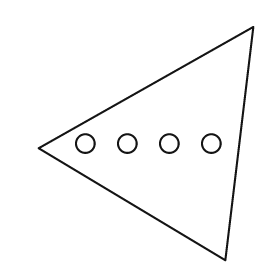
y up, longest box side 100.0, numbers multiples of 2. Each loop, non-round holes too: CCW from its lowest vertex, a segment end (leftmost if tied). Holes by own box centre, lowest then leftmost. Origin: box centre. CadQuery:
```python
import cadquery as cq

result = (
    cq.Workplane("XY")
    .moveTo(34.0, -50.0)
    .lineTo(46.0, 50.0)
    .lineTo(-46.0, -2.0)
    .close()
    .moveTo(-26.0, 0.0)
    .circle(4.0)
    .moveTo(-8.0, 0.0)
    .circle(4.0)
    .moveTo(10.0, 0.0)
    .circle(4.0)
    .moveTo(28.0, 0.0)
    .circle(4.0)
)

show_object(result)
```